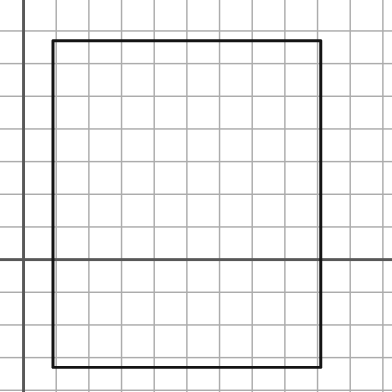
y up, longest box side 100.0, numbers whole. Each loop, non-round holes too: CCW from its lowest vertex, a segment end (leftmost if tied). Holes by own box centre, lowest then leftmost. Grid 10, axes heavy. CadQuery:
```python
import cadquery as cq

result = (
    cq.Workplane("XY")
    .moveTo(9.0, -33.0)
    .lineTo(91.0, -33.0)
    .lineTo(91.0, 67.0)
    .lineTo(9.0, 67.0)
    .close()
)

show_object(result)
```